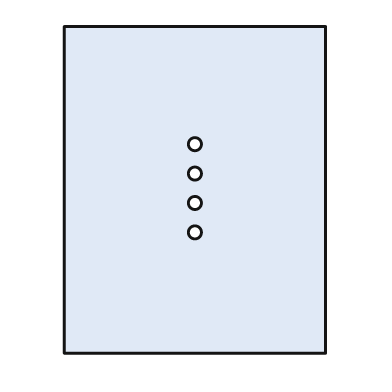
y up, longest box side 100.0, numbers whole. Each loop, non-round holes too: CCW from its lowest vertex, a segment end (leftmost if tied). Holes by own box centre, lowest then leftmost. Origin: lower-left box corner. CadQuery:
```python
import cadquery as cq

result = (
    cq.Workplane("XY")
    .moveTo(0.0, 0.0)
    .lineTo(80.0, 0.0)
    .lineTo(80.0, 100.0)
    .lineTo(0.0, 100.0)
    .close()
    .moveTo(40.0, 37.0)
    .circle(2.0)
    .moveTo(40.0, 46.0)
    .circle(2.0)
    .moveTo(40.0, 55.0)
    .circle(2.0)
    .moveTo(40.0, 64.0)
    .circle(2.0)
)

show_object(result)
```